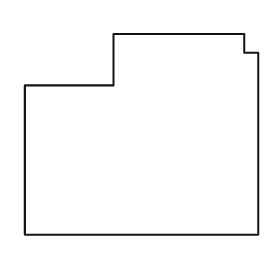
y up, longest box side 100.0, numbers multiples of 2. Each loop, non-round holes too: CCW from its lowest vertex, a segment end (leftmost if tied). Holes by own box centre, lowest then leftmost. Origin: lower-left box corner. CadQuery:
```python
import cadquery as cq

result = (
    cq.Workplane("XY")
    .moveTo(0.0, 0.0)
    .lineTo(100.0, 0.0)
    .lineTo(100.0, 78.0)
    .lineTo(94.0, 78.0)
    .lineTo(94.0, 86.0)
    .lineTo(38.0, 86.0)
    .lineTo(38.0, 64.0)
    .lineTo(0.0, 64.0)
    .close()
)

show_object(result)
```